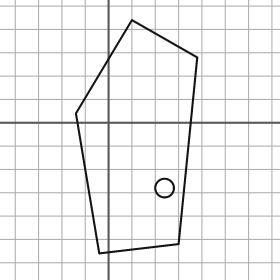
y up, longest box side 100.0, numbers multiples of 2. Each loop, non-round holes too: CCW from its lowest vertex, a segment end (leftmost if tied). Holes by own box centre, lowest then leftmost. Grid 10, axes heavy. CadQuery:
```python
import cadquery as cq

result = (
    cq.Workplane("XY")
    .moveTo(-4.0, -56.0)
    .lineTo(30.0, -52.0)
    .lineTo(38.0, 28.0)
    .lineTo(10.0, 44.0)
    .lineTo(-14.0, 4.0)
    .close()
    .moveTo(24.0, -28.0)
    .circle(4.0)
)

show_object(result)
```